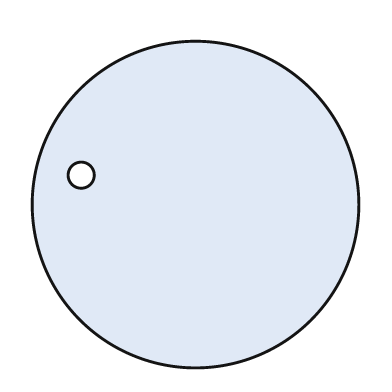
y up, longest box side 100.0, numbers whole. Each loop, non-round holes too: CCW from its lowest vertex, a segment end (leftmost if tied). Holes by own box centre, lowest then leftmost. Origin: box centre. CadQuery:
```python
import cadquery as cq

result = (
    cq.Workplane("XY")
    .moveTo(0.0, 0.0)
    .circle(50.0)
    .moveTo(-35.0, 9.0)
    .circle(4.0)
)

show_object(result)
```